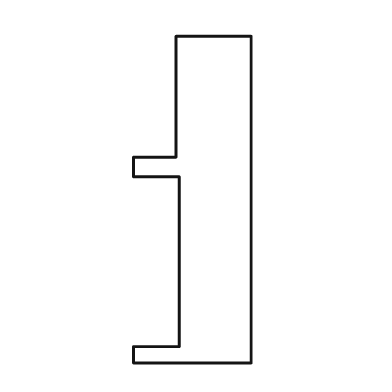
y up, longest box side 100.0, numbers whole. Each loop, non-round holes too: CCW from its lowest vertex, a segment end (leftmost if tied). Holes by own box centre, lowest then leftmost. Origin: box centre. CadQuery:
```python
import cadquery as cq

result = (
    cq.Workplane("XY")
    .moveTo(-18.0, -50.0)
    .lineTo(18.0, -50.0)
    .lineTo(18.0, 50.0)
    .lineTo(-5.0, 50.0)
    .lineTo(-5.0, 13.0)
    .lineTo(-18.0, 13.0)
    .lineTo(-18.0, 7.0)
    .lineTo(-4.0, 7.0)
    .lineTo(-4.0, -45.0)
    .lineTo(-18.0, -45.0)
    .close()
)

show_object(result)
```